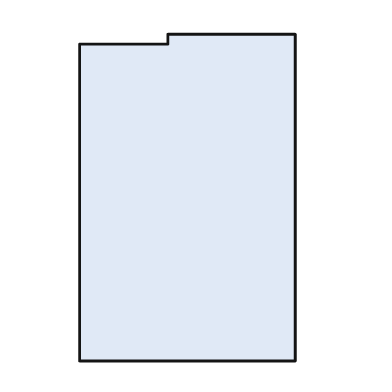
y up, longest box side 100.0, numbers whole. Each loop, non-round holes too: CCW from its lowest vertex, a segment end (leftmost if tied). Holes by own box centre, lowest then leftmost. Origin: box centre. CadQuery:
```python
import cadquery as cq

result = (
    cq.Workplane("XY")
    .moveTo(-33.0, -50.0)
    .lineTo(33.0, -50.0)
    .lineTo(33.0, 50.0)
    .lineTo(-6.0, 50.0)
    .lineTo(-6.0, 47.0)
    .lineTo(-33.0, 47.0)
    .close()
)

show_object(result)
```